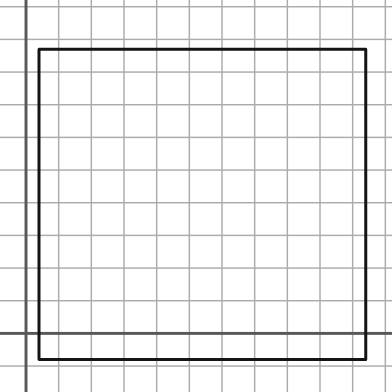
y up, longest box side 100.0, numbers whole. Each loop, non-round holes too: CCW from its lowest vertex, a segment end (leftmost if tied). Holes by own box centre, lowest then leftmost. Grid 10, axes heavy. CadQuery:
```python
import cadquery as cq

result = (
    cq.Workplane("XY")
    .moveTo(4.0, -8.0)
    .lineTo(104.0, -8.0)
    .lineTo(104.0, 87.0)
    .lineTo(4.0, 87.0)
    .close()
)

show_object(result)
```